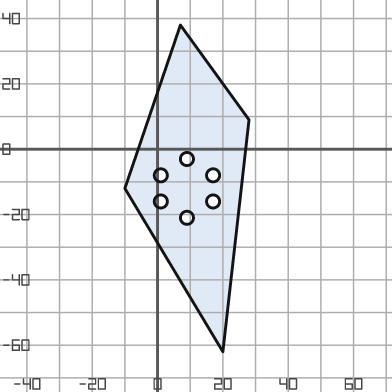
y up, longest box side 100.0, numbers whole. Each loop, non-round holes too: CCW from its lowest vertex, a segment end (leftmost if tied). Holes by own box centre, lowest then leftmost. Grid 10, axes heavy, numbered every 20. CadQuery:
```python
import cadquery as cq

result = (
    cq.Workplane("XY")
    .moveTo(20.0, -62.0)
    .lineTo(28.0, 9.0)
    .lineTo(7.0, 38.0)
    .lineTo(-10.0, -12.0)
    .close()
    .moveTo(9.0, -21.0)
    .circle(2.0)
    .moveTo(1.0, -16.0)
    .circle(2.0)
    .moveTo(17.0, -16.0)
    .circle(2.0)
    .moveTo(1.0, -8.0)
    .circle(2.0)
    .moveTo(17.0, -8.0)
    .circle(2.0)
    .moveTo(9.0, -3.0)
    .circle(2.0)
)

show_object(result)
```